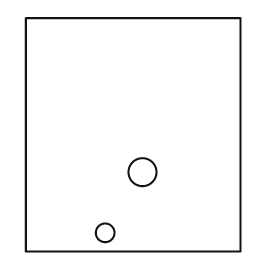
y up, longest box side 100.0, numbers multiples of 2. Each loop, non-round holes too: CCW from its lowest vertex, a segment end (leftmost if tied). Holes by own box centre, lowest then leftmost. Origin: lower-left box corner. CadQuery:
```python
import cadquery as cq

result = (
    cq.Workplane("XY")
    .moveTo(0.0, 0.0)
    .lineTo(92.0, 0.0)
    .lineTo(92.0, 100.0)
    .lineTo(0.0, 100.0)
    .close()
    .moveTo(34.0, 8.0)
    .circle(4.0)
    .moveTo(50.0, 34.0)
    .circle(6.0)
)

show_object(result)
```